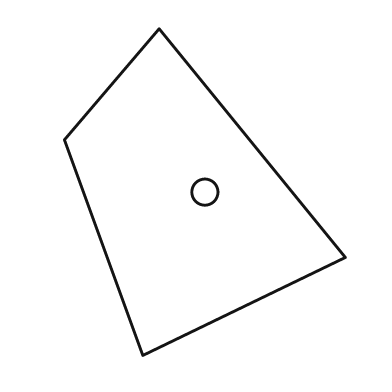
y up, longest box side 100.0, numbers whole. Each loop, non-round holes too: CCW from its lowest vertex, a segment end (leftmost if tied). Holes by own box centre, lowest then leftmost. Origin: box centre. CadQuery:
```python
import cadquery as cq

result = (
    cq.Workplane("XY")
    .moveTo(-19.0, -50.0)
    .lineTo(43.0, -20.0)
    .lineTo(-14.0, 50.0)
    .lineTo(-43.0, 16.0)
    .close()
    .moveTo(0.0, 0.0)
    .circle(4.0)
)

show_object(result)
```